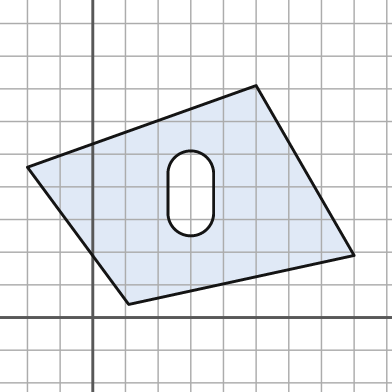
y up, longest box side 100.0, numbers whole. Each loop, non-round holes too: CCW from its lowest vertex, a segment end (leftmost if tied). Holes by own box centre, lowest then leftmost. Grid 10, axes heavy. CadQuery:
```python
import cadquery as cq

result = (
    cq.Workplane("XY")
    .moveTo(11.0, 4.0)
    .lineTo(80.0, 19.0)
    .lineTo(50.0, 71.0)
    .lineTo(-20.0, 46.0)
    .close()
    .moveTo(23.0, 32.0)
    .threePointArc((30.0, 25.0), (37.0, 32.0))
    .lineTo(37.0, 44.0)
    .threePointArc((30.0, 51.0), (23.0, 44.0))
    .close()
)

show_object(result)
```